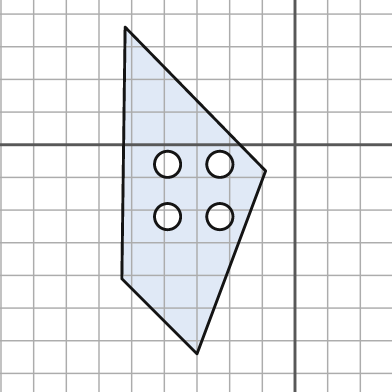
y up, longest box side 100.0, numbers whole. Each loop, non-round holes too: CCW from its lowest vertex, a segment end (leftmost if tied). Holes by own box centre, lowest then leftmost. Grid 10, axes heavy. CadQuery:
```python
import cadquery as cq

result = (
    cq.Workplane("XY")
    .moveTo(-30.0, -64.0)
    .lineTo(-9.0, -8.0)
    .lineTo(-52.0, 36.0)
    .lineTo(-53.0, -41.0)
    .close()
    .moveTo(-39.0, -22.0)
    .circle(4.0)
    .moveTo(-23.0, -22.0)
    .circle(4.0)
    .moveTo(-39.0, -6.0)
    .circle(4.0)
    .moveTo(-23.0, -6.0)
    .circle(4.0)
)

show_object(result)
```